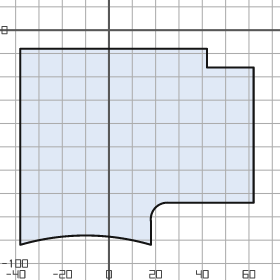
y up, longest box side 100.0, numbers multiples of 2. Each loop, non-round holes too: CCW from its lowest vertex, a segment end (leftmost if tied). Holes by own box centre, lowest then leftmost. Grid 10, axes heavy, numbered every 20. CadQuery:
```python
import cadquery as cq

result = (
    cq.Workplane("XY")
    .moveTo(-38.0, -92.0)
    .threePointArc((-10.0, -88.0), (18.0, -92.0))
    .lineTo(18.0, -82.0)
    .threePointArc((20.0, -76.0), (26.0, -74.0))
    .lineTo(62.0, -74.0)
    .lineTo(62.0, -16.0)
    .lineTo(42.0, -16.0)
    .lineTo(42.0, -8.0)
    .lineTo(-38.0, -8.0)
    .close()
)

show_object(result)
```